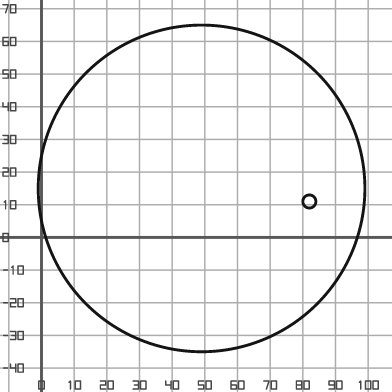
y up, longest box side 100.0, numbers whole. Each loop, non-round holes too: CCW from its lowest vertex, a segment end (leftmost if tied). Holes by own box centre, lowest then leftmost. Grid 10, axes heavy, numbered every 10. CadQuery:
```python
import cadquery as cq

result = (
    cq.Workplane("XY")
    .moveTo(49.0, 15.0)
    .circle(50.0)
    .moveTo(82.0, 11.0)
    .circle(2.0)
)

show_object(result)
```